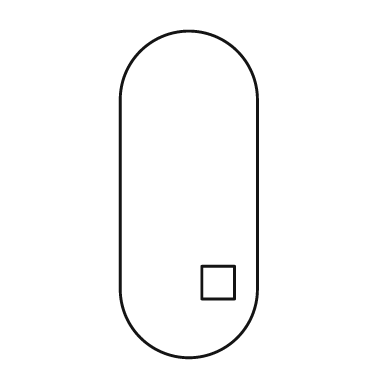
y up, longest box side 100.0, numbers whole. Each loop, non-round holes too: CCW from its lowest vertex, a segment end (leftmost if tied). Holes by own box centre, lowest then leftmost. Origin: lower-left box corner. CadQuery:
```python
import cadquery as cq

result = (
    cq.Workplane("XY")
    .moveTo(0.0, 21.0)
    .threePointArc((21.0, 0.0), (42.0, 21.0))
    .lineTo(42.0, 79.0)
    .threePointArc((21.0, 100.0), (0.0, 79.0))
    .close()
    .moveTo(25.0, 18.0)
    .lineTo(35.0, 18.0)
    .lineTo(35.0, 28.0)
    .lineTo(25.0, 28.0)
    .close()
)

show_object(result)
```